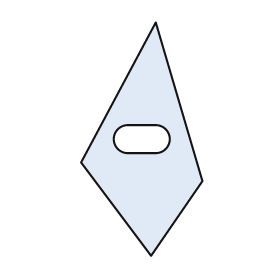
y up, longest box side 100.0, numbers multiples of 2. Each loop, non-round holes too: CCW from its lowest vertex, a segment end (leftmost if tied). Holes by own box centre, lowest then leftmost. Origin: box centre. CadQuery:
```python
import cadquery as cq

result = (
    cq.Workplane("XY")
    .moveTo(4.0, -50.0)
    .lineTo(26.0, -18.0)
    .lineTo(6.0, 50.0)
    .lineTo(-26.0, -10.0)
    .close()
    .moveTo(-6.0, -6.0)
    .lineTo(6.0, -6.0)
    .threePointArc((12.0, 0.0), (6.0, 6.0))
    .lineTo(-6.0, 6.0)
    .threePointArc((-12.0, 0.0), (-6.0, -6.0))
    .close()
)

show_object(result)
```